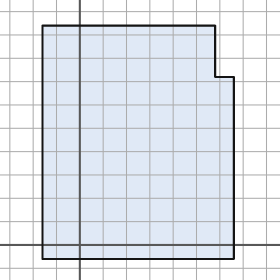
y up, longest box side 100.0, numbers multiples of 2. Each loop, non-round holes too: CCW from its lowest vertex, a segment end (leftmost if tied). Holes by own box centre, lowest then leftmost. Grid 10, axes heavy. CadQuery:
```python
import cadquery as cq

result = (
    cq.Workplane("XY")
    .moveTo(-16.0, -6.0)
    .lineTo(66.0, -6.0)
    .lineTo(66.0, 72.0)
    .lineTo(58.0, 72.0)
    .lineTo(58.0, 94.0)
    .lineTo(-16.0, 94.0)
    .close()
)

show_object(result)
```